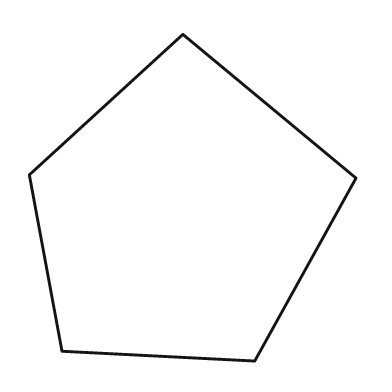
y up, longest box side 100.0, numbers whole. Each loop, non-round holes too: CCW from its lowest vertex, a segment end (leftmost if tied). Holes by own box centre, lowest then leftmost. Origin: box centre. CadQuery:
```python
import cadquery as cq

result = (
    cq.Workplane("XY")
    .moveTo(19.0, -50.0)
    .lineTo(50.0, 6.0)
    .lineTo(-3.0, 50.0)
    .lineTo(-50.0, 7.0)
    .lineTo(-40.0, -47.0)
    .close()
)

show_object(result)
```